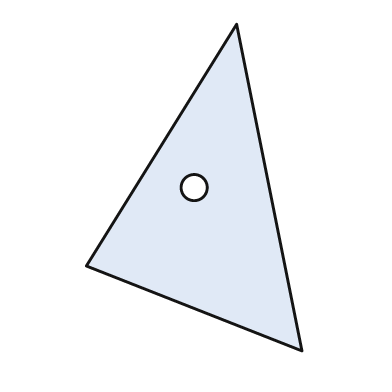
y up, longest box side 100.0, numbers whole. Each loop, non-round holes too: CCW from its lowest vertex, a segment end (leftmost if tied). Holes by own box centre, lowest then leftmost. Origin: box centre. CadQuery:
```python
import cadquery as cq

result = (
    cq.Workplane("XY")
    .moveTo(33.0, -50.0)
    .lineTo(13.0, 50.0)
    .lineTo(-33.0, -24.0)
    .close()
    .moveTo(0.0, 0.0)
    .circle(4.0)
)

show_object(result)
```